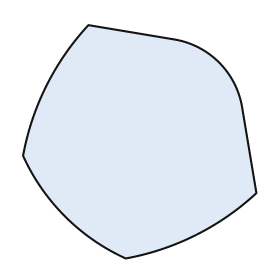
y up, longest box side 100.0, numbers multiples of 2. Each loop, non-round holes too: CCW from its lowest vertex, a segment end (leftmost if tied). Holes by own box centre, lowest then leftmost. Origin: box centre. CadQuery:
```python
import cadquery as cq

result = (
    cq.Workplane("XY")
    .moveTo(-6.0, -50.0)
    .threePointArc((24.0, -40.0), (50.0, -22.0))
    .lineTo(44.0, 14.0)
    .threePointArc((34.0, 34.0), (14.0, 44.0))
    .lineTo(-22.0, 50.0)
    .threePointArc((-40.0, 24.0), (-50.0, -6.0))
    .threePointArc((-32.0, -32.0), (-6.0, -50.0))
    .close()
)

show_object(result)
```